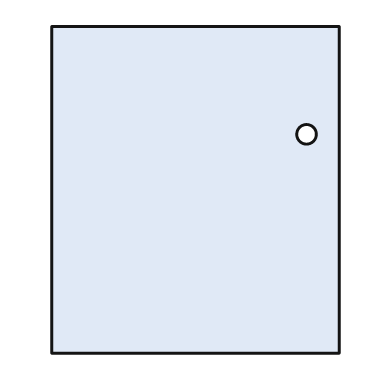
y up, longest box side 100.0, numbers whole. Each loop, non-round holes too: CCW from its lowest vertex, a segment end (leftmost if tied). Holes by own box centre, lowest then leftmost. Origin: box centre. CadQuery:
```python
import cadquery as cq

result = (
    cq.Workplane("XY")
    .moveTo(-44.0, -50.0)
    .lineTo(44.0, -50.0)
    .lineTo(44.0, 50.0)
    .lineTo(-44.0, 50.0)
    .close()
    .moveTo(34.0, 17.0)
    .circle(3.0)
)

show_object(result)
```